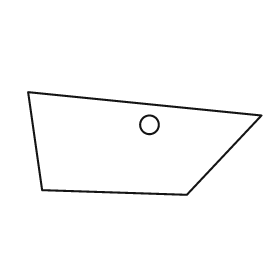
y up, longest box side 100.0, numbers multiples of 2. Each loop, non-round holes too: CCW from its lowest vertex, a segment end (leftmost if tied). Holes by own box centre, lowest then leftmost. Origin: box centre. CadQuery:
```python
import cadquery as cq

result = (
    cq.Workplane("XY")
    .moveTo(18.0, -22.0)
    .lineTo(50.0, 12.0)
    .lineTo(-50.0, 22.0)
    .lineTo(-44.0, -20.0)
    .close()
    .moveTo(2.0, 8.0)
    .circle(4.0)
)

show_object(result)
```